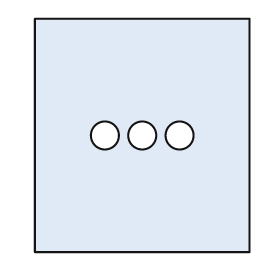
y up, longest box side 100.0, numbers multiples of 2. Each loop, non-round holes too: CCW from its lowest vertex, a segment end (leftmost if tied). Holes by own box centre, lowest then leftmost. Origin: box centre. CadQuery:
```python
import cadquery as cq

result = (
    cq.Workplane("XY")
    .moveTo(-46.0, -50.0)
    .lineTo(46.0, -50.0)
    .lineTo(46.0, 50.0)
    .lineTo(-46.0, 50.0)
    .close()
    .moveTo(-16.0, 0.0)
    .circle(6.0)
    .moveTo(0.0, 0.0)
    .circle(6.0)
    .moveTo(16.0, 0.0)
    .circle(6.0)
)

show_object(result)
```